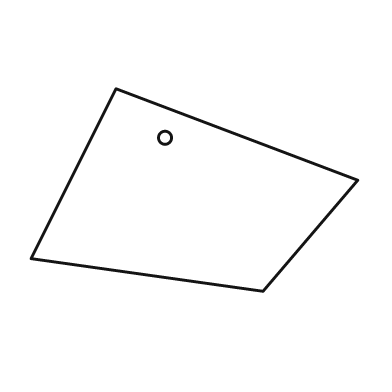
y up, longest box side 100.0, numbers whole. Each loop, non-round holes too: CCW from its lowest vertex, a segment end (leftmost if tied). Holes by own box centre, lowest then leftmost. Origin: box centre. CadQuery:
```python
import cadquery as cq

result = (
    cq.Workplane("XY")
    .moveTo(21.0, -31.0)
    .lineTo(50.0, 3.0)
    .lineTo(-24.0, 31.0)
    .lineTo(-50.0, -21.0)
    .close()
    .moveTo(-9.0, 16.0)
    .circle(2.0)
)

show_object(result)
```